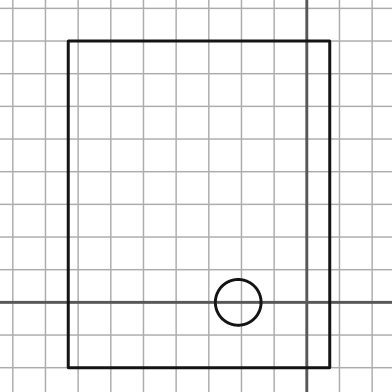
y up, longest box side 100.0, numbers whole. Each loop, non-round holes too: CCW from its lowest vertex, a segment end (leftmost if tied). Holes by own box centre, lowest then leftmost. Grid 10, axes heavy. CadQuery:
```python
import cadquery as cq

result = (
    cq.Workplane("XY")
    .moveTo(-73.0, -20.0)
    .lineTo(7.0, -20.0)
    .lineTo(7.0, 80.0)
    .lineTo(-73.0, 80.0)
    .close()
    .moveTo(-21.0, 0.0)
    .circle(7.0)
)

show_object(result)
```